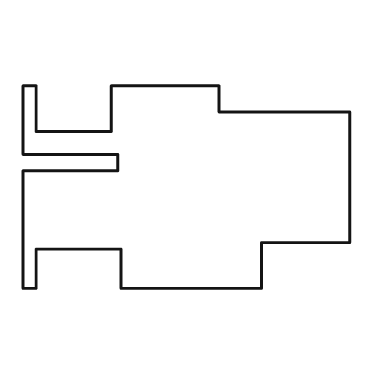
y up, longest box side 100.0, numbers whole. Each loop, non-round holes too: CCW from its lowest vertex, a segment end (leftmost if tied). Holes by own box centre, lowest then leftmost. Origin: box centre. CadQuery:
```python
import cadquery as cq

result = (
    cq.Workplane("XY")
    .moveTo(-50.0, -31.0)
    .lineTo(-46.0, -31.0)
    .lineTo(-46.0, -19.0)
    .lineTo(-20.0, -19.0)
    .lineTo(-20.0, -31.0)
    .lineTo(23.0, -31.0)
    .lineTo(23.0, -17.0)
    .lineTo(50.0, -17.0)
    .lineTo(50.0, 23.0)
    .lineTo(10.0, 23.0)
    .lineTo(10.0, 31.0)
    .lineTo(-23.0, 31.0)
    .lineTo(-23.0, 17.0)
    .lineTo(-46.0, 17.0)
    .lineTo(-46.0, 31.0)
    .lineTo(-50.0, 31.0)
    .lineTo(-50.0, 10.0)
    .lineTo(-21.0, 10.0)
    .lineTo(-21.0, 5.0)
    .lineTo(-50.0, 5.0)
    .close()
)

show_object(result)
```